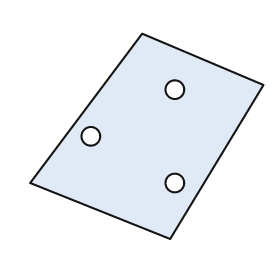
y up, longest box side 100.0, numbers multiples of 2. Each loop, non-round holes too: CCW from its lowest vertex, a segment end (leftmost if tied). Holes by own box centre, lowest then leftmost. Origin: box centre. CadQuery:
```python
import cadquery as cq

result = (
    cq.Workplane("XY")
    .moveTo(10.0, -44.0)
    .lineTo(50.0, 22.0)
    .lineTo(-2.0, 44.0)
    .lineTo(-50.0, -20.0)
    .close()
    .moveTo(12.0, -20.0)
    .circle(4.0)
    .moveTo(-24.0, 0.0)
    .circle(4.0)
    .moveTo(12.0, 20.0)
    .circle(4.0)
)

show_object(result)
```